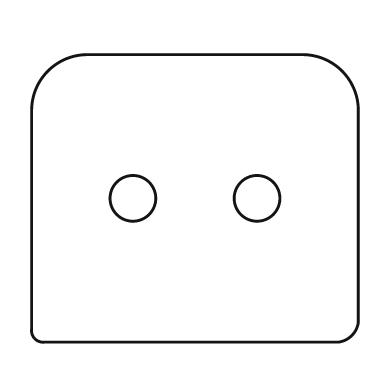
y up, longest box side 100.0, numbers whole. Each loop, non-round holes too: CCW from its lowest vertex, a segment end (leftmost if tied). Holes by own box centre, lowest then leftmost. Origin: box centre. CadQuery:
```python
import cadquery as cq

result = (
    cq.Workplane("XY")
    .moveTo(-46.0, -44.0)
    .lineTo(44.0, -44.0)
    .threePointArc((48.0, -42.0), (50.0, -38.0))
    .lineTo(50.0, 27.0)
    .threePointArc((45.0, 39.0), (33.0, 44.0))
    .lineTo(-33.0, 44.0)
    .threePointArc((-45.0, 39.0), (-50.0, 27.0))
    .lineTo(-50.0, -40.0)
    .threePointArc((-49.0, -43.0), (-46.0, -44.0))
    .close()
    .moveTo(-19.0, 0.0)
    .circle(7.0)
    .moveTo(19.0, 0.0)
    .circle(7.0)
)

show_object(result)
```